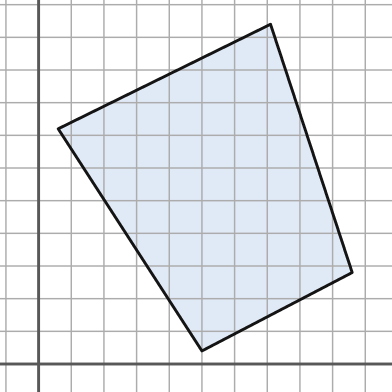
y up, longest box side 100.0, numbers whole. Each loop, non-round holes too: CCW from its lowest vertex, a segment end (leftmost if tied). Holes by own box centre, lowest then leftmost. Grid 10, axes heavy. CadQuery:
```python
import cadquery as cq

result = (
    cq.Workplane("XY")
    .moveTo(50.0, 4.0)
    .lineTo(96.0, 28.0)
    .lineTo(71.0, 104.0)
    .lineTo(6.0, 72.0)
    .close()
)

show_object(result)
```